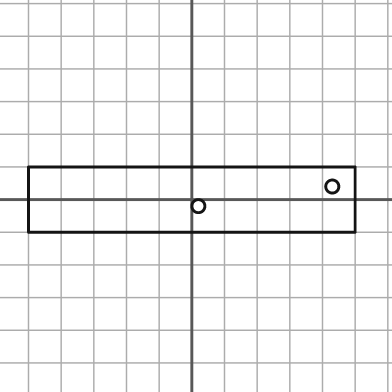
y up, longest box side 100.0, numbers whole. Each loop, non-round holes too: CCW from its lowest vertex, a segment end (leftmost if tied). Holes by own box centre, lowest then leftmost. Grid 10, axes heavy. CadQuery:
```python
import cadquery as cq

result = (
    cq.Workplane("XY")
    .moveTo(-50.0, -10.0)
    .lineTo(50.0, -10.0)
    .lineTo(50.0, 10.0)
    .lineTo(-50.0, 10.0)
    .close()
    .moveTo(2.0, -2.0)
    .circle(2.0)
    .moveTo(43.0, 4.0)
    .circle(2.0)
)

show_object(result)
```